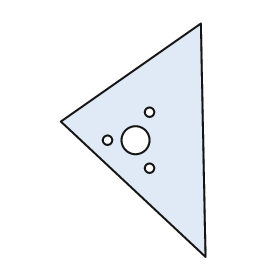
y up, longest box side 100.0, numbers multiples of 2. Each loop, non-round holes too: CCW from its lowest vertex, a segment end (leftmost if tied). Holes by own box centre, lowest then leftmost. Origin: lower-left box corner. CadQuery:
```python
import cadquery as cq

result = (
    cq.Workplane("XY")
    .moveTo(62.0, 0.0)
    .lineTo(60.0, 100.0)
    .lineTo(0.0, 58.0)
    .close()
    .moveTo(38.0, 38.0)
    .circle(2.0)
    .moveTo(20.0, 50.0)
    .circle(2.0)
    .moveTo(32.0, 50.0)
    .circle(6.0)
    .moveTo(38.0, 62.0)
    .circle(2.0)
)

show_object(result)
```